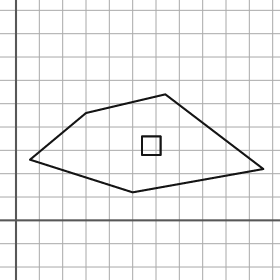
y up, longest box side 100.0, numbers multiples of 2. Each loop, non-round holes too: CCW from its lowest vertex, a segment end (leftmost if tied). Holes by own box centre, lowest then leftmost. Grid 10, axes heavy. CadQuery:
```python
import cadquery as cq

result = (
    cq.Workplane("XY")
    .moveTo(50.0, 12.0)
    .lineTo(106.0, 22.0)
    .lineTo(64.0, 54.0)
    .lineTo(30.0, 46.0)
    .lineTo(6.0, 26.0)
    .close()
    .moveTo(54.0, 28.0)
    .lineTo(62.0, 28.0)
    .lineTo(62.0, 36.0)
    .lineTo(54.0, 36.0)
    .close()
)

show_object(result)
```